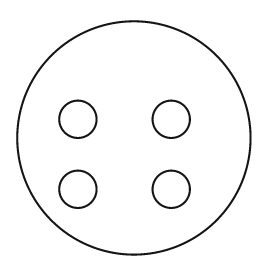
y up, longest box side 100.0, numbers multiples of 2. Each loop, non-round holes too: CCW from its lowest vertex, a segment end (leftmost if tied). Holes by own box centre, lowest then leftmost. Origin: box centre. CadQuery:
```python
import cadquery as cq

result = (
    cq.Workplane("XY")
    .moveTo(0.0, 0.0)
    .circle(50.0)
    .moveTo(-24.0, -22.0)
    .circle(8.0)
    .moveTo(16.0, -22.0)
    .circle(8.0)
    .moveTo(-24.0, 8.0)
    .circle(8.0)
    .moveTo(16.0, 8.0)
    .circle(8.0)
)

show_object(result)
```